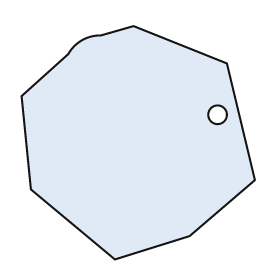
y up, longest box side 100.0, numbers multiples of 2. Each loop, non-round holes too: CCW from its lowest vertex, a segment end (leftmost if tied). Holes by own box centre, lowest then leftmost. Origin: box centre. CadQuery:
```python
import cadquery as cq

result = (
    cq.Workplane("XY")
    .moveTo(-10.0, -50.0)
    .lineTo(22.0, -40.0)
    .lineTo(50.0, -16.0)
    .lineTo(38.0, 34.0)
    .lineTo(-2.0, 50.0)
    .lineTo(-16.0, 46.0)
    .threePointArc((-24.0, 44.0), (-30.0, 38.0))
    .lineTo(-50.0, 20.0)
    .lineTo(-46.0, -20.0)
    .close()
    .moveTo(34.0, 12.0)
    .circle(4.0)
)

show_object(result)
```